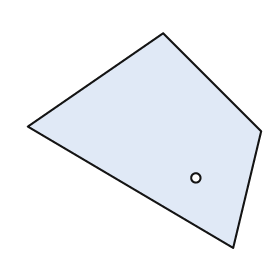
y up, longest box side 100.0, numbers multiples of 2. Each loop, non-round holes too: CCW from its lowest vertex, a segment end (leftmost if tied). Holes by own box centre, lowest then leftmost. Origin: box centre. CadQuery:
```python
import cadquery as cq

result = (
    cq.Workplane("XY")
    .moveTo(38.0, -46.0)
    .lineTo(50.0, 4.0)
    .lineTo(8.0, 46.0)
    .lineTo(-50.0, 6.0)
    .close()
    .moveTo(22.0, -16.0)
    .circle(2.0)
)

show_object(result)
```